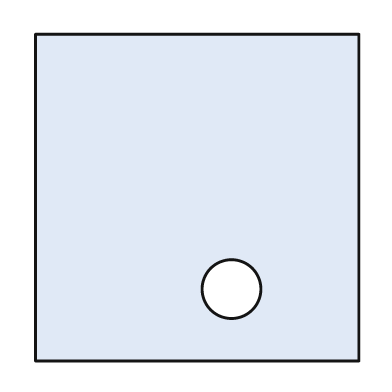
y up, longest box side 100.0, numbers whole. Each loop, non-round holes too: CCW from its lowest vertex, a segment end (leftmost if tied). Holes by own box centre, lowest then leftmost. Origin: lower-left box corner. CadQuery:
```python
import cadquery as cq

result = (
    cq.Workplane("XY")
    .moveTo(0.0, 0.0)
    .lineTo(99.0, 0.0)
    .lineTo(99.0, 100.0)
    .lineTo(0.0, 100.0)
    .close()
    .moveTo(60.0, 22.0)
    .circle(9.0)
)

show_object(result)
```